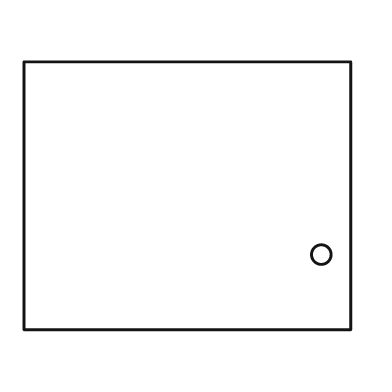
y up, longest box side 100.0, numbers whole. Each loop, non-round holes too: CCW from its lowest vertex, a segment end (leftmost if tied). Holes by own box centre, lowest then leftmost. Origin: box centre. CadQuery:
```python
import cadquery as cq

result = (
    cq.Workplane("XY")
    .moveTo(-50.0, -41.0)
    .lineTo(50.0, -41.0)
    .lineTo(50.0, 41.0)
    .lineTo(-50.0, 41.0)
    .close()
    .moveTo(41.0, -18.0)
    .circle(3.0)
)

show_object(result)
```